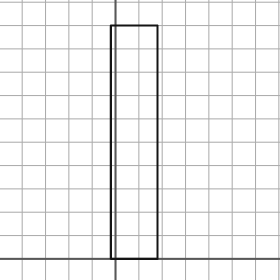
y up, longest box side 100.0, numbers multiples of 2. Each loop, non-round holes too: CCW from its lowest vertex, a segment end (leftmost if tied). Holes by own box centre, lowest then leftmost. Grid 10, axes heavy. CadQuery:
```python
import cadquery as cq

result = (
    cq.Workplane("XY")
    .moveTo(-2.0, 0.0)
    .lineTo(18.0, 0.0)
    .lineTo(18.0, 100.0)
    .lineTo(-2.0, 100.0)
    .close()
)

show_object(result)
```